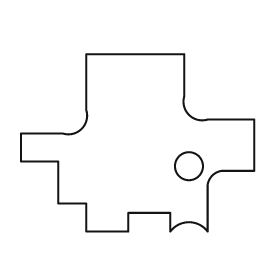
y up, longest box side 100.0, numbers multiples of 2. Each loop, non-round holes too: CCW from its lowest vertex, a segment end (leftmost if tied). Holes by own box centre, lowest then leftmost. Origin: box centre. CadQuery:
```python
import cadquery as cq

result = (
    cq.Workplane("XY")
    .moveTo(-22.0, -38.0)
    .lineTo(-4.0, -38.0)
    .lineTo(-4.0, -30.0)
    .lineTo(14.0, -30.0)
    .lineTo(14.0, -38.0)
    .threePointArc((22.0, -34.0), (30.0, -38.0))
    .lineTo(30.0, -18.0)
    .threePointArc((32.0, -14.0), (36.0, -12.0))
    .lineTo(50.0, -12.0)
    .lineTo(50.0, 10.0)
    .lineTo(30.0, 10.0)
    .threePointArc((22.0, 12.0), (20.0, 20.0))
    .lineTo(20.0, 38.0)
    .lineTo(-22.0, 38.0)
    .lineTo(-22.0, 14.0)
    .threePointArc((-24.0, 6.0), (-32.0, 4.0))
    .lineTo(-50.0, 4.0)
    .lineTo(-50.0, -8.0)
    .lineTo(-34.0, -8.0)
    .lineTo(-34.0, -26.0)
    .lineTo(-22.0, -26.0)
    .close()
    .moveTo(22.0, -10.0)
    .circle(6.0)
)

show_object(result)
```